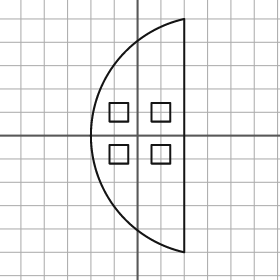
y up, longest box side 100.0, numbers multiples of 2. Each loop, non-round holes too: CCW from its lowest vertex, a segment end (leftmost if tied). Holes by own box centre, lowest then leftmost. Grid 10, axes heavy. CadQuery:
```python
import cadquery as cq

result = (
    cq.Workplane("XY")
    .moveTo(20.0, -50.0)
    .lineTo(20.0, 50.0)
    .threePointArc((-20.0, 0.0), (20.0, -50.0))
    .close()
    .moveTo(-12.0, -12.0)
    .lineTo(-4.0, -12.0)
    .lineTo(-4.0, -4.0)
    .lineTo(-12.0, -4.0)
    .close()
    .moveTo(6.0, -12.0)
    .lineTo(14.0, -12.0)
    .lineTo(14.0, -4.0)
    .lineTo(6.0, -4.0)
    .close()
    .moveTo(-12.0, 6.0)
    .lineTo(-4.0, 6.0)
    .lineTo(-4.0, 14.0)
    .lineTo(-12.0, 14.0)
    .close()
    .moveTo(6.0, 6.0)
    .lineTo(14.0, 6.0)
    .lineTo(14.0, 14.0)
    .lineTo(6.0, 14.0)
    .close()
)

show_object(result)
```